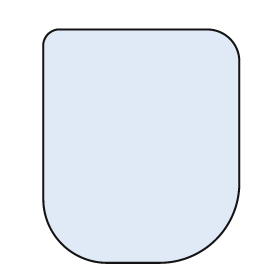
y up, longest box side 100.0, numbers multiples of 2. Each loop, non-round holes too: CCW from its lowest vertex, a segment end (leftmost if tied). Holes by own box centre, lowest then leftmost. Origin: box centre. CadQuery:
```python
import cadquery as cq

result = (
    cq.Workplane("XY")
    .moveTo(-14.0, -50.0)
    .lineTo(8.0, -50.0)
    .threePointArc((32.0, -40.0), (42.0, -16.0))
    .lineTo(42.0, 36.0)
    .threePointArc((38.0, 46.0), (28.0, 50.0))
    .lineTo(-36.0, 50.0)
    .threePointArc((-40.0, 48.0), (-42.0, 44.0))
    .lineTo(-42.0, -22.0)
    .threePointArc((-34.0, -42.0), (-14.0, -50.0))
    .close()
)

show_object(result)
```